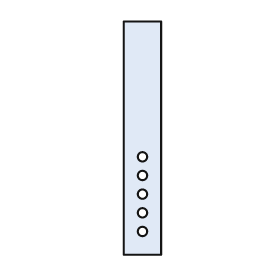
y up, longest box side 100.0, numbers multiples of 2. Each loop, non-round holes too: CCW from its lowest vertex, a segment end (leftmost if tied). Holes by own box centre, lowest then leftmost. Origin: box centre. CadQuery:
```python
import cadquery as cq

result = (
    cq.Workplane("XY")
    .moveTo(-8.0, -50.0)
    .lineTo(8.0, -50.0)
    .lineTo(8.0, 50.0)
    .lineTo(-8.0, 50.0)
    .close()
    .moveTo(0.0, -40.0)
    .circle(2.0)
    .moveTo(0.0, -32.0)
    .circle(2.0)
    .moveTo(0.0, -24.0)
    .circle(2.0)
    .moveTo(0.0, -16.0)
    .circle(2.0)
    .moveTo(0.0, -8.0)
    .circle(2.0)
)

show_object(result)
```